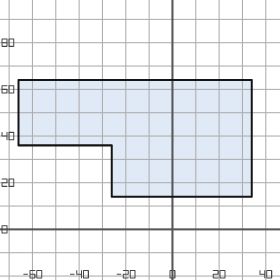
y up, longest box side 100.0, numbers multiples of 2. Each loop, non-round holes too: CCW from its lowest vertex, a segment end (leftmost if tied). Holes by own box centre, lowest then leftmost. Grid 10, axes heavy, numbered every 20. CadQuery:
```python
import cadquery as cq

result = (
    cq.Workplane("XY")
    .moveTo(-26.0, 14.0)
    .lineTo(34.0, 14.0)
    .lineTo(34.0, 64.0)
    .lineTo(-66.0, 64.0)
    .lineTo(-66.0, 36.0)
    .lineTo(-26.0, 36.0)
    .close()
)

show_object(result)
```